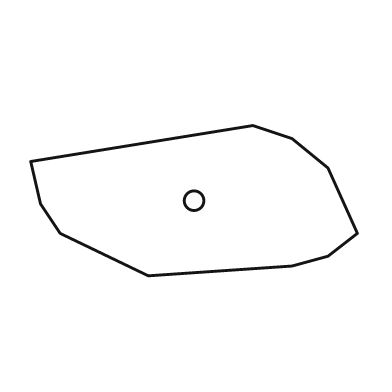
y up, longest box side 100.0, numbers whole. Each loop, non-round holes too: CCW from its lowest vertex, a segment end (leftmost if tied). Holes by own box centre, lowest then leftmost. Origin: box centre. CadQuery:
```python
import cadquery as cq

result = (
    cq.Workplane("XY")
    .moveTo(-14.0, -23.0)
    .lineTo(30.0, -20.0)
    .lineTo(41.0, -17.0)
    .lineTo(50.0, -10.0)
    .lineTo(41.0, 10.0)
    .lineTo(30.0, 19.0)
    .lineTo(18.0, 23.0)
    .lineTo(-50.0, 12.0)
    .lineTo(-47.0, -1.0)
    .lineTo(-41.0, -10.0)
    .close()
    .moveTo(0.0, 0.0)
    .circle(3.0)
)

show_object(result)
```